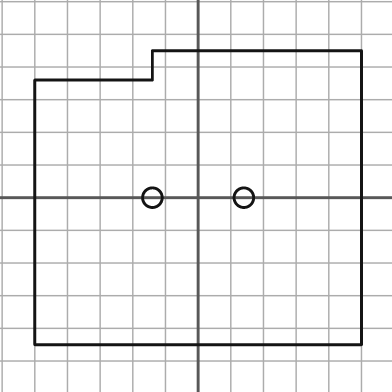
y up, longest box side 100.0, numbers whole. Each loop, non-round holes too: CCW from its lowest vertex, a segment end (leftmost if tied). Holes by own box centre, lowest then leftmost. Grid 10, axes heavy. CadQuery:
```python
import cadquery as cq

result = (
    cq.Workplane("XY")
    .moveTo(-50.0, -45.0)
    .lineTo(50.0, -45.0)
    .lineTo(50.0, 45.0)
    .lineTo(-14.0, 45.0)
    .lineTo(-14.0, 36.0)
    .lineTo(-50.0, 36.0)
    .close()
    .moveTo(-14.0, 0.0)
    .circle(3.0)
    .moveTo(14.0, 0.0)
    .circle(3.0)
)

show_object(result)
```